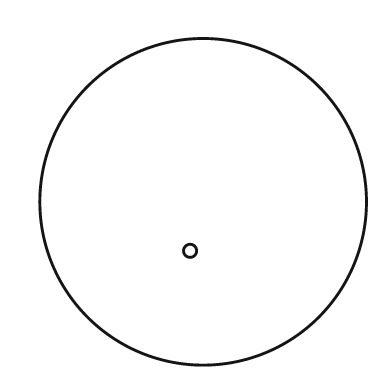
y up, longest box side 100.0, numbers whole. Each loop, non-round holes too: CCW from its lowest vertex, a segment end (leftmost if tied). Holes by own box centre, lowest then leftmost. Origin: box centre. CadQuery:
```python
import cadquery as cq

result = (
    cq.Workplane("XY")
    .moveTo(0.0, 0.0)
    .circle(50.0)
    .moveTo(-4.0, -15.0)
    .circle(2.0)
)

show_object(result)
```